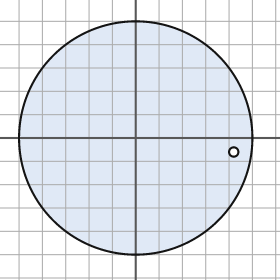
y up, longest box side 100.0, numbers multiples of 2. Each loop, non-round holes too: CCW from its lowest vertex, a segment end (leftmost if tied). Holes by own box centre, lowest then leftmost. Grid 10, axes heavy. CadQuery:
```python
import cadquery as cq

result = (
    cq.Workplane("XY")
    .moveTo(0.0, 0.0)
    .circle(50.0)
    .moveTo(42.0, -6.0)
    .circle(2.0)
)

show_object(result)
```